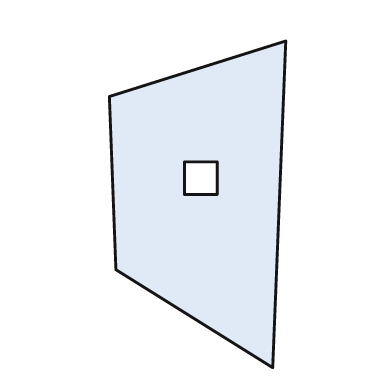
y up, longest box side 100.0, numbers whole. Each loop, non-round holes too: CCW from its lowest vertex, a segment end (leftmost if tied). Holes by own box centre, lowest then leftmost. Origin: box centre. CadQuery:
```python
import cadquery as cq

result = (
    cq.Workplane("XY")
    .moveTo(23.0, -50.0)
    .lineTo(27.0, 50.0)
    .lineTo(-27.0, 33.0)
    .lineTo(-25.0, -20.0)
    .close()
    .moveTo(-4.0, 3.0)
    .lineTo(6.0, 3.0)
    .lineTo(6.0, 13.0)
    .lineTo(-4.0, 13.0)
    .close()
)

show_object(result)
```